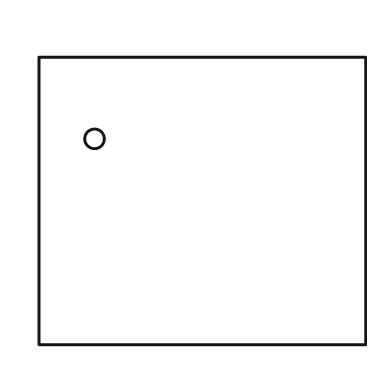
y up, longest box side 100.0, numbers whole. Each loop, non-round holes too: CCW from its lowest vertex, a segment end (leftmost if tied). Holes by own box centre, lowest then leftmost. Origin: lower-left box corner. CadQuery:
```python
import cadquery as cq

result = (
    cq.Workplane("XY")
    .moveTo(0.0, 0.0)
    .lineTo(100.0, 0.0)
    .lineTo(100.0, 88.0)
    .lineTo(0.0, 88.0)
    .close()
    .moveTo(17.0, 63.0)
    .circle(3.0)
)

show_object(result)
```